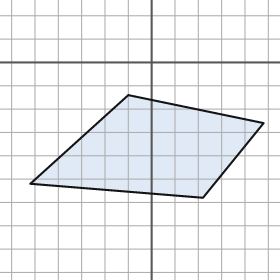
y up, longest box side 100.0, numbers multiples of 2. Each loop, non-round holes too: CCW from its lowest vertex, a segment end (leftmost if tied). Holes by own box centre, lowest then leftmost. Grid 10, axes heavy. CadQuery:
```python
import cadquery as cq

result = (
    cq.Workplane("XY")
    .moveTo(22.0, -58.0)
    .lineTo(48.0, -26.0)
    .lineTo(-10.0, -14.0)
    .lineTo(-52.0, -52.0)
    .close()
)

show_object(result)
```